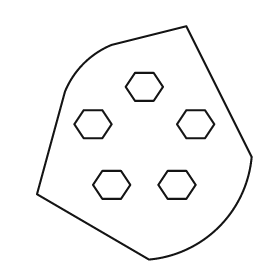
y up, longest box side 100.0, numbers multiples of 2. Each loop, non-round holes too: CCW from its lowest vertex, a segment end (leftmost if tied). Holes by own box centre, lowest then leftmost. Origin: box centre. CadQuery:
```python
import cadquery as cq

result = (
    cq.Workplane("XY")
    .moveTo(2.0, -50.0)
    .threePointArc((32.0, -36.0), (46.0, -6.0))
    .lineTo(18.0, 50.0)
    .lineTo(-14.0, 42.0)
    .threePointArc((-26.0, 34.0), (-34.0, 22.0))
    .lineTo(-46.0, -22.0)
    .close()
    .moveTo(-18.0, -24.0)
    .lineTo(-10.0, -24.0)
    .lineTo(-6.0, -18.0)
    .lineTo(-10.0, -12.0)
    .lineTo(-18.0, -12.0)
    .lineTo(-22.0, -18.0)
    .close()
    .moveTo(10.0, -24.0)
    .lineTo(18.0, -24.0)
    .lineTo(22.0, -18.0)
    .lineTo(18.0, -12.0)
    .lineTo(10.0, -12.0)
    .lineTo(6.0, -18.0)
    .close()
    .moveTo(-26.0, 2.0)
    .lineTo(-18.0, 2.0)
    .lineTo(-14.0, 8.0)
    .lineTo(-18.0, 14.0)
    .lineTo(-26.0, 14.0)
    .lineTo(-30.0, 8.0)
    .close()
    .moveTo(18.0, 2.0)
    .lineTo(26.0, 2.0)
    .lineTo(30.0, 8.0)
    .lineTo(26.0, 14.0)
    .lineTo(18.0, 14.0)
    .lineTo(14.0, 8.0)
    .close()
    .moveTo(-4.0, 18.0)
    .lineTo(4.0, 18.0)
    .lineTo(8.0, 24.0)
    .lineTo(4.0, 30.0)
    .lineTo(-4.0, 30.0)
    .lineTo(-8.0, 24.0)
    .close()
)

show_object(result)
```